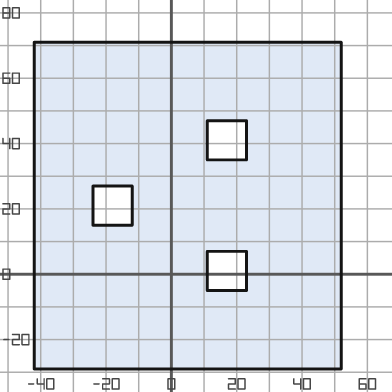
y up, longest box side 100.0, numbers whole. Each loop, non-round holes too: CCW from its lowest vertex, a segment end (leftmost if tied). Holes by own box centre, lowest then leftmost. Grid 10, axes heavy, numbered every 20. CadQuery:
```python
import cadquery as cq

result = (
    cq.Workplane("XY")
    .moveTo(-42.0, -29.0)
    .lineTo(52.0, -29.0)
    .lineTo(52.0, 71.0)
    .lineTo(-42.0, 71.0)
    .close()
    .moveTo(11.0, -5.0)
    .lineTo(23.0, -5.0)
    .lineTo(23.0, 7.0)
    .lineTo(11.0, 7.0)
    .close()
    .moveTo(-24.0, 15.0)
    .lineTo(-12.0, 15.0)
    .lineTo(-12.0, 27.0)
    .lineTo(-24.0, 27.0)
    .close()
    .moveTo(11.0, 35.0)
    .lineTo(23.0, 35.0)
    .lineTo(23.0, 47.0)
    .lineTo(11.0, 47.0)
    .close()
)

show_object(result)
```